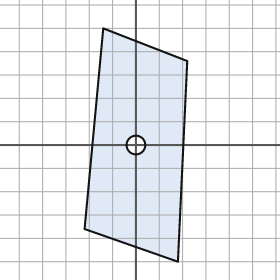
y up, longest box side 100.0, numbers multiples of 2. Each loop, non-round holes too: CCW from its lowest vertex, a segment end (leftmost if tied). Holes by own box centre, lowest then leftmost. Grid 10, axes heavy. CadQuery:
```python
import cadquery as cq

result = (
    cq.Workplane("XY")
    .moveTo(18.0, -50.0)
    .lineTo(22.0, 36.0)
    .lineTo(-14.0, 50.0)
    .lineTo(-22.0, -36.0)
    .close()
    .moveTo(0.0, 0.0)
    .circle(4.0)
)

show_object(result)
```